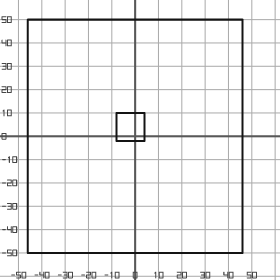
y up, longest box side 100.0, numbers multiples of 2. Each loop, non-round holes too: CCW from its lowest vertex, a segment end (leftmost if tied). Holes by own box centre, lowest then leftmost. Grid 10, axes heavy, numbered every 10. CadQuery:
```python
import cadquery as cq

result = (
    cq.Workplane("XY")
    .moveTo(-46.0, -50.0)
    .lineTo(46.0, -50.0)
    .lineTo(46.0, 50.0)
    .lineTo(-46.0, 50.0)
    .close()
    .moveTo(-8.0, -2.0)
    .lineTo(4.0, -2.0)
    .lineTo(4.0, 10.0)
    .lineTo(-8.0, 10.0)
    .close()
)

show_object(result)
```